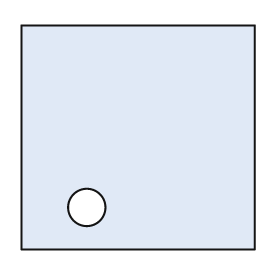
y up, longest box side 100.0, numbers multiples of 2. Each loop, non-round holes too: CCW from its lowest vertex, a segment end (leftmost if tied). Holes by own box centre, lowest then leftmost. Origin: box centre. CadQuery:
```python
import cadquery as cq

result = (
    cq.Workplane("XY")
    .moveTo(-50.0, -48.0)
    .lineTo(50.0, -48.0)
    .lineTo(50.0, 48.0)
    .lineTo(-50.0, 48.0)
    .close()
    .moveTo(-22.0, -30.0)
    .circle(8.0)
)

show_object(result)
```